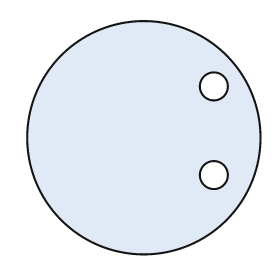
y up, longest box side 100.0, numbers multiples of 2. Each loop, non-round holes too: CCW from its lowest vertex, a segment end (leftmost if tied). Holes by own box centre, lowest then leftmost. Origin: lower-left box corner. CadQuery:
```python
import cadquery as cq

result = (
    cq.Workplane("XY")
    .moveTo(50.0, 50.0)
    .circle(50.0)
    .moveTo(80.0, 34.0)
    .circle(6.0)
    .moveTo(80.0, 72.0)
    .circle(6.0)
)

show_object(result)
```